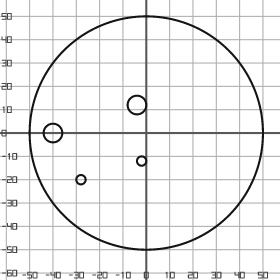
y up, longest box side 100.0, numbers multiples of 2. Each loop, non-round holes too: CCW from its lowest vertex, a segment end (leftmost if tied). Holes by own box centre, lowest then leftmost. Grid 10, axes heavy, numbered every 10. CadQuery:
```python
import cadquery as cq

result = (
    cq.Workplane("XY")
    .moveTo(0.0, 0.0)
    .circle(50.0)
    .moveTo(-28.0, -20.0)
    .circle(2.0)
    .moveTo(-2.0, -12.0)
    .circle(2.0)
    .moveTo(-40.0, 0.0)
    .circle(4.0)
    .moveTo(-4.0, 12.0)
    .circle(4.0)
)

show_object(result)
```